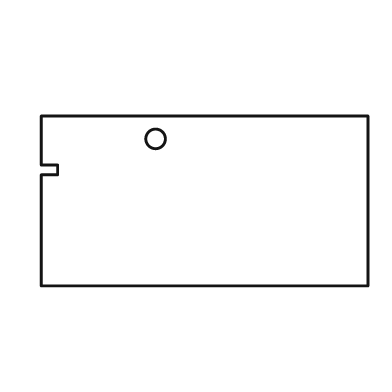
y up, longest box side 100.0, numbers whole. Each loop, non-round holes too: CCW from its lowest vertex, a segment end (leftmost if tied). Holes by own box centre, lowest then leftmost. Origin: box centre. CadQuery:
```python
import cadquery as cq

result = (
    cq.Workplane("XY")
    .moveTo(-50.0, -26.0)
    .lineTo(50.0, -26.0)
    .lineTo(50.0, 26.0)
    .lineTo(-50.0, 26.0)
    .lineTo(-50.0, 11.0)
    .lineTo(-45.0, 11.0)
    .lineTo(-45.0, 8.0)
    .lineTo(-50.0, 8.0)
    .close()
    .moveTo(-15.0, 19.0)
    .circle(3.0)
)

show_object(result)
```